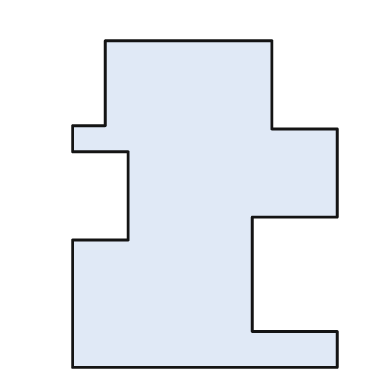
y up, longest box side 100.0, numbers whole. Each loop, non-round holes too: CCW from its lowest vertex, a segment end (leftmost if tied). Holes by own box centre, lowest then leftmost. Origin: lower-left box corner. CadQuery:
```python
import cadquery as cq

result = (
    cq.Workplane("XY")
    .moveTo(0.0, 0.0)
    .lineTo(81.0, 0.0)
    .lineTo(81.0, 11.0)
    .lineTo(55.0, 11.0)
    .lineTo(55.0, 46.0)
    .lineTo(81.0, 46.0)
    .lineTo(81.0, 73.0)
    .lineTo(61.0, 73.0)
    .lineTo(61.0, 100.0)
    .lineTo(10.0, 100.0)
    .lineTo(10.0, 74.0)
    .lineTo(0.0, 74.0)
    .lineTo(0.0, 66.0)
    .lineTo(17.0, 66.0)
    .lineTo(17.0, 39.0)
    .lineTo(0.0, 39.0)
    .close()
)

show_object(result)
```